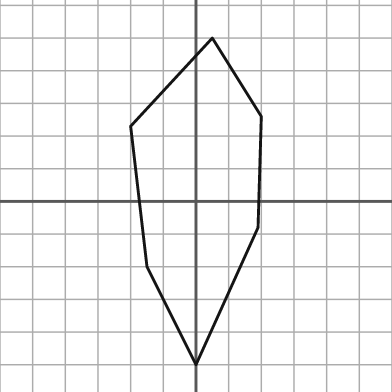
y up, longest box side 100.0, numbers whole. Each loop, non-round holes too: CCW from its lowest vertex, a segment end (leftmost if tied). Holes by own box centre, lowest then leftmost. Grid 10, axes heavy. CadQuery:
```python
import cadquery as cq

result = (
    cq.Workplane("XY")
    .moveTo(0.0, -50.0)
    .lineTo(19.0, -8.0)
    .lineTo(20.0, 26.0)
    .lineTo(5.0, 50.0)
    .lineTo(-20.0, 23.0)
    .lineTo(-15.0, -20.0)
    .close()
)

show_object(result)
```